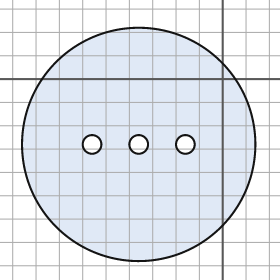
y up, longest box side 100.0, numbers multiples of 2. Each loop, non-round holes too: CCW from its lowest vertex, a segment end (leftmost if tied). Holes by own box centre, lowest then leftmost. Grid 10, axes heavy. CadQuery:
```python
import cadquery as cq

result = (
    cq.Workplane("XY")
    .moveTo(-36.0, -28.0)
    .circle(50.0)
    .moveTo(-56.0, -28.0)
    .circle(4.0)
    .moveTo(-36.0, -28.0)
    .circle(4.0)
    .moveTo(-16.0, -28.0)
    .circle(4.0)
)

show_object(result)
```